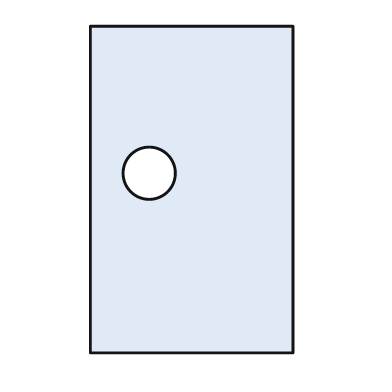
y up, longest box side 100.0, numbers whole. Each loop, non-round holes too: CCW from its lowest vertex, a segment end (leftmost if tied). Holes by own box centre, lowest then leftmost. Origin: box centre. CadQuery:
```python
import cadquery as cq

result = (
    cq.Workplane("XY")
    .moveTo(-31.0, -50.0)
    .lineTo(31.0, -50.0)
    .lineTo(31.0, 50.0)
    .lineTo(-31.0, 50.0)
    .close()
    .moveTo(-13.0, 5.0)
    .circle(8.0)
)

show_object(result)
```